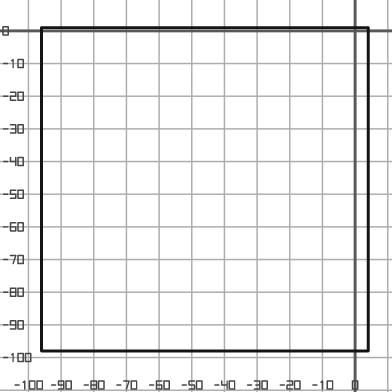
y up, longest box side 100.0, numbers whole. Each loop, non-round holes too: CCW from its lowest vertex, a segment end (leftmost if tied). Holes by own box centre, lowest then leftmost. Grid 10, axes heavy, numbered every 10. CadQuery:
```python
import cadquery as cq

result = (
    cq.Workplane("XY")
    .moveTo(-96.0, -98.0)
    .lineTo(4.0, -98.0)
    .lineTo(4.0, 1.0)
    .lineTo(-96.0, 1.0)
    .close()
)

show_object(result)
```